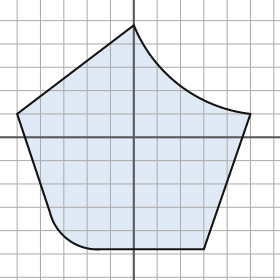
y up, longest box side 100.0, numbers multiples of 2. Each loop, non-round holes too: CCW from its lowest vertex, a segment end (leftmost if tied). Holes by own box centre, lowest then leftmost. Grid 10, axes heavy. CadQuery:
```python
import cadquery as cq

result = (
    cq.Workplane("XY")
    .moveTo(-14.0, -48.0)
    .lineTo(30.0, -48.0)
    .lineTo(50.0, 10.0)
    .threePointArc((20.0, 22.0), (0.0, 48.0))
    .lineTo(-50.0, 10.0)
    .lineTo(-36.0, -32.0)
    .threePointArc((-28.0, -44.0), (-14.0, -48.0))
    .close()
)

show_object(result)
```